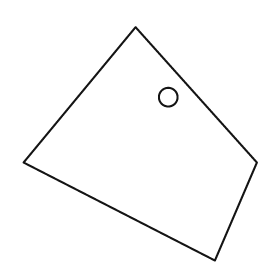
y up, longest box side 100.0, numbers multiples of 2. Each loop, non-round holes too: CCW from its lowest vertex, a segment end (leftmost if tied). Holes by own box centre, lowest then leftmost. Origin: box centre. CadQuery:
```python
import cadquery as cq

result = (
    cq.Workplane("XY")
    .moveTo(32.0, -50.0)
    .lineTo(50.0, -8.0)
    .lineTo(-2.0, 50.0)
    .lineTo(-50.0, -8.0)
    .close()
    .moveTo(12.0, 20.0)
    .circle(4.0)
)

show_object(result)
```